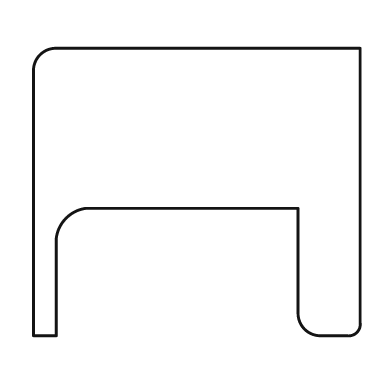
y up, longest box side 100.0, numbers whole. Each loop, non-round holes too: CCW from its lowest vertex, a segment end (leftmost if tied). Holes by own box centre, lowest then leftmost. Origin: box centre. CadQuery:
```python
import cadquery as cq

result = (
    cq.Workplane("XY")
    .moveTo(-50.0, -44.0)
    .lineTo(-43.0, -44.0)
    .lineTo(-43.0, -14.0)
    .threePointArc((-40.0, -8.0), (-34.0, -5.0))
    .lineTo(31.0, -5.0)
    .lineTo(31.0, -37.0)
    .threePointArc((33.0, -42.0), (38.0, -44.0))
    .lineTo(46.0, -44.0)
    .threePointArc((49.0, -43.0), (50.0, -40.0))
    .lineTo(50.0, 44.0)
    .lineTo(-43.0, 44.0)
    .threePointArc((-48.0, 42.0), (-50.0, 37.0))
    .close()
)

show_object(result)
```